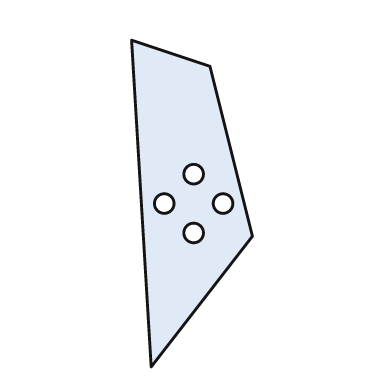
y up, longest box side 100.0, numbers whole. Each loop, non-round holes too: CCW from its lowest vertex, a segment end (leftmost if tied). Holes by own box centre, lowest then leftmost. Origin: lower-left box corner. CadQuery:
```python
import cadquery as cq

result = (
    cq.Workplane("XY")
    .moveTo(6.0, 0.0)
    .lineTo(37.0, 40.0)
    .lineTo(24.0, 92.0)
    .lineTo(0.0, 100.0)
    .close()
    .moveTo(19.0, 41.0)
    .circle(3.0)
    .moveTo(10.0, 50.0)
    .circle(3.0)
    .moveTo(28.0, 50.0)
    .circle(3.0)
    .moveTo(19.0, 59.0)
    .circle(3.0)
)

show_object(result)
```